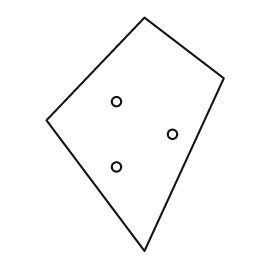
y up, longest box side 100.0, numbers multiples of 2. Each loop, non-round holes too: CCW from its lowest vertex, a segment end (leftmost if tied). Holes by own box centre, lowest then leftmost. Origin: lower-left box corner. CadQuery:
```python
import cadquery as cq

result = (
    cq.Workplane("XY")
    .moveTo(42.0, 0.0)
    .lineTo(76.0, 74.0)
    .lineTo(42.0, 100.0)
    .lineTo(0.0, 56.0)
    .close()
    .moveTo(30.0, 36.0)
    .circle(2.0)
    .moveTo(54.0, 50.0)
    .circle(2.0)
    .moveTo(30.0, 64.0)
    .circle(2.0)
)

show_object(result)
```